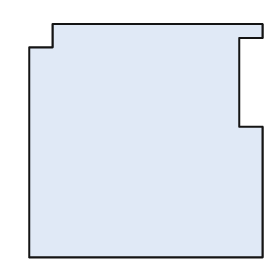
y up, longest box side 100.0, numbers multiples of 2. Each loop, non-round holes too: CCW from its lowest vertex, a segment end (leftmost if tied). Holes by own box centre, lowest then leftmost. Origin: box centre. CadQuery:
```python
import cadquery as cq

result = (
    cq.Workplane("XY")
    .moveTo(-50.0, -50.0)
    .lineTo(50.0, -50.0)
    .lineTo(50.0, 6.0)
    .lineTo(40.0, 6.0)
    .lineTo(40.0, 44.0)
    .lineTo(50.0, 44.0)
    .lineTo(50.0, 50.0)
    .lineTo(-40.0, 50.0)
    .lineTo(-40.0, 40.0)
    .lineTo(-50.0, 40.0)
    .close()
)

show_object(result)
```